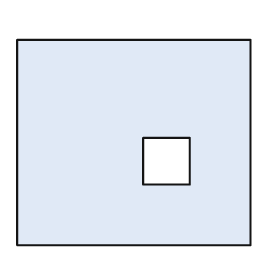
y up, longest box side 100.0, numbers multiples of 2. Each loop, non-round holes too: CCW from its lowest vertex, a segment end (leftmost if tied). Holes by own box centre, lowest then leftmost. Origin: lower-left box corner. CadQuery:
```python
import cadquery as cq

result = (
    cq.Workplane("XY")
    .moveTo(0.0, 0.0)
    .lineTo(100.0, 0.0)
    .lineTo(100.0, 88.0)
    .lineTo(0.0, 88.0)
    .close()
    .moveTo(54.0, 26.0)
    .lineTo(74.0, 26.0)
    .lineTo(74.0, 46.0)
    .lineTo(54.0, 46.0)
    .close()
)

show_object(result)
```